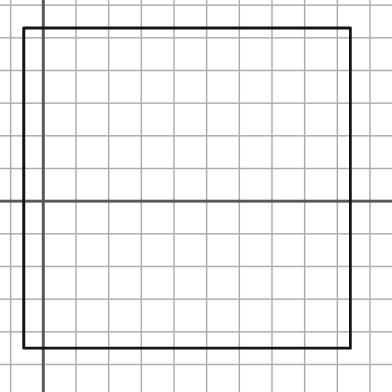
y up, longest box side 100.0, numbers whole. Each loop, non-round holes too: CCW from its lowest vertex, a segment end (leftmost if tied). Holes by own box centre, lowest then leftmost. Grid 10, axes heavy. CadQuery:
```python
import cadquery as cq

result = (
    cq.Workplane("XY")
    .moveTo(-6.0, -45.0)
    .lineTo(94.0, -45.0)
    .lineTo(94.0, 53.0)
    .lineTo(-6.0, 53.0)
    .close()
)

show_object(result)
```